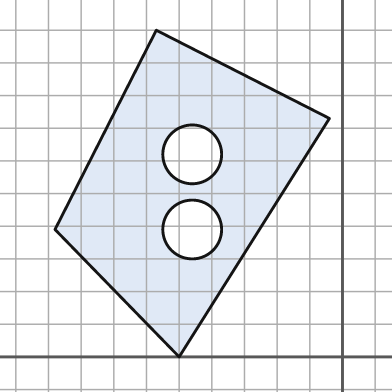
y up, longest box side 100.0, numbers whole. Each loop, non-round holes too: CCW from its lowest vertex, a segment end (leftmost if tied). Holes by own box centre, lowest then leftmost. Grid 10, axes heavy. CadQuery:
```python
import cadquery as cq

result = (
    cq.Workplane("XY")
    .moveTo(-50.0, 0.0)
    .lineTo(-4.0, 73.0)
    .lineTo(-57.0, 100.0)
    .lineTo(-88.0, 39.0)
    .close()
    .moveTo(-46.0, 39.0)
    .circle(9.0)
    .moveTo(-46.0, 62.0)
    .circle(9.0)
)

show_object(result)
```